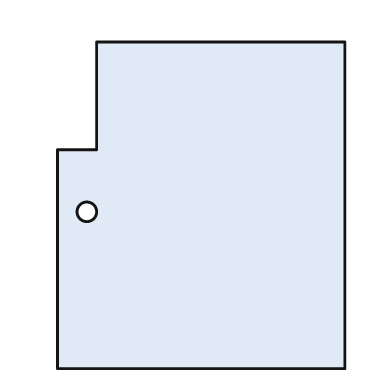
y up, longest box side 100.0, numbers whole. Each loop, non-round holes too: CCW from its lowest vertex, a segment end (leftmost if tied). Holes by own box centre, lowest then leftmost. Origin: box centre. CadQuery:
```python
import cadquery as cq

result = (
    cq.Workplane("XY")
    .moveTo(-44.0, -50.0)
    .lineTo(44.0, -50.0)
    .lineTo(44.0, 50.0)
    .lineTo(-32.0, 50.0)
    .lineTo(-32.0, 17.0)
    .lineTo(-44.0, 17.0)
    .close()
    .moveTo(-35.0, -2.0)
    .circle(3.0)
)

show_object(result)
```